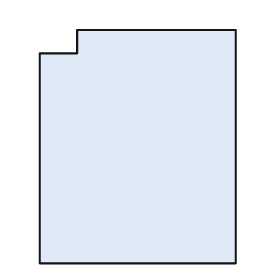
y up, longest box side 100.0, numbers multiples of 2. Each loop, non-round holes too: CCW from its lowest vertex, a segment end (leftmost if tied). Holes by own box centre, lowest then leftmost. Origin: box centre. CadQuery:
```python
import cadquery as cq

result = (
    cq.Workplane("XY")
    .moveTo(-42.0, -50.0)
    .lineTo(42.0, -50.0)
    .lineTo(42.0, 50.0)
    .lineTo(-26.0, 50.0)
    .lineTo(-26.0, 40.0)
    .lineTo(-42.0, 40.0)
    .close()
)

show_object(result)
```